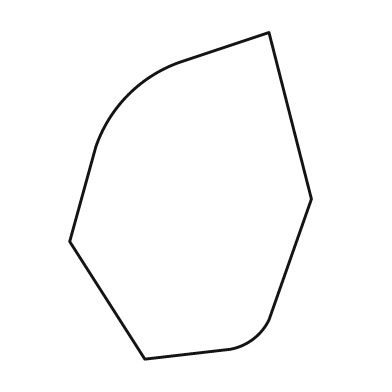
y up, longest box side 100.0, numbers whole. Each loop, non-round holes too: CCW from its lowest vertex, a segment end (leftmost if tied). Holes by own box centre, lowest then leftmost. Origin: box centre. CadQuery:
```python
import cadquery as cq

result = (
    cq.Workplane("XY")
    .moveTo(-14.0, -50.0)
    .lineTo(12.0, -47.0)
    .threePointArc((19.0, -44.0), (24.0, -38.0))
    .lineTo(37.0, -1.0)
    .lineTo(24.0, 50.0)
    .lineTo(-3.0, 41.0)
    .threePointArc((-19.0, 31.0), (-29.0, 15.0))
    .lineTo(-37.0, -14.0)
    .close()
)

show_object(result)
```